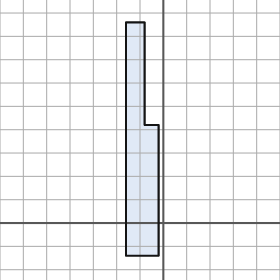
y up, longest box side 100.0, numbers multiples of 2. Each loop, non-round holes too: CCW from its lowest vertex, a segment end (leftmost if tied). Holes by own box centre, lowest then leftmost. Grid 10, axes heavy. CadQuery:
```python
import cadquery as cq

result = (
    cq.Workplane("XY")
    .moveTo(-16.0, -14.0)
    .lineTo(-2.0, -14.0)
    .lineTo(-2.0, 42.0)
    .lineTo(-8.0, 42.0)
    .lineTo(-8.0, 86.0)
    .lineTo(-16.0, 86.0)
    .close()
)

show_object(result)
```